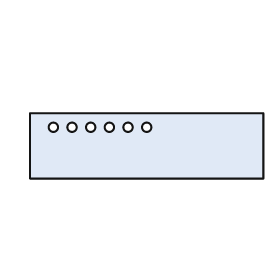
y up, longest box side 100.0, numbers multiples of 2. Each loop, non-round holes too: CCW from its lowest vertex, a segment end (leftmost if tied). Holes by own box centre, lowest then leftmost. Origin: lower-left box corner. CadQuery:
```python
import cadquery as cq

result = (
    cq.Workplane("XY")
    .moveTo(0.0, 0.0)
    .lineTo(100.0, 0.0)
    .lineTo(100.0, 28.0)
    .lineTo(0.0, 28.0)
    .close()
    .moveTo(10.0, 22.0)
    .circle(2.0)
    .moveTo(18.0, 22.0)
    .circle(2.0)
    .moveTo(26.0, 22.0)
    .circle(2.0)
    .moveTo(34.0, 22.0)
    .circle(2.0)
    .moveTo(42.0, 22.0)
    .circle(2.0)
    .moveTo(50.0, 22.0)
    .circle(2.0)
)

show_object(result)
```